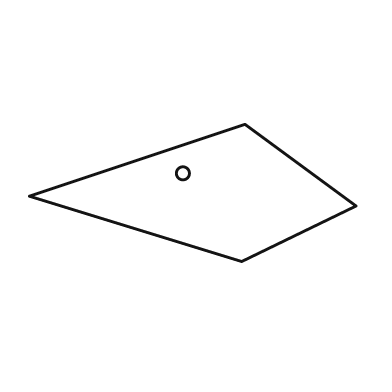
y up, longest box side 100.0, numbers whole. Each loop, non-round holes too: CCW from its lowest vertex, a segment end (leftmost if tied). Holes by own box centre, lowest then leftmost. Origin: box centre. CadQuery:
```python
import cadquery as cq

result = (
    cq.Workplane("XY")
    .moveTo(15.0, -21.0)
    .lineTo(50.0, -4.0)
    .lineTo(16.0, 21.0)
    .lineTo(-50.0, -1.0)
    .close()
    .moveTo(-3.0, 6.0)
    .circle(2.0)
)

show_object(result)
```